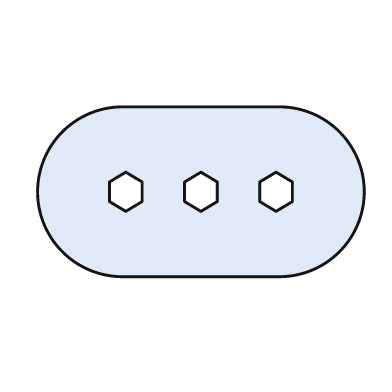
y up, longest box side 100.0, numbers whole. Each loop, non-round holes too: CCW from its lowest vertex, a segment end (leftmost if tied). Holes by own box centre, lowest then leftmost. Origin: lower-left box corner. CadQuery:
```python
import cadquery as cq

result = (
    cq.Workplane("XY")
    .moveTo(26.0, 0.0)
    .lineTo(74.0, 0.0)
    .threePointArc((100.0, 26.0), (74.0, 52.0))
    .lineTo(26.0, 52.0)
    .threePointArc((0.0, 26.0), (26.0, 0.0))
    .close()
    .moveTo(27.0, 20.0)
    .lineTo(32.0, 23.0)
    .lineTo(32.0, 29.0)
    .lineTo(27.0, 32.0)
    .lineTo(22.0, 29.0)
    .lineTo(22.0, 23.0)
    .close()
    .moveTo(50.0, 20.0)
    .lineTo(55.0, 23.0)
    .lineTo(55.0, 29.0)
    .lineTo(50.0, 32.0)
    .lineTo(45.0, 29.0)
    .lineTo(45.0, 23.0)
    .close()
    .moveTo(73.0, 20.0)
    .lineTo(78.0, 23.0)
    .lineTo(78.0, 29.0)
    .lineTo(73.0, 32.0)
    .lineTo(68.0, 29.0)
    .lineTo(68.0, 23.0)
    .close()
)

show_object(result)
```